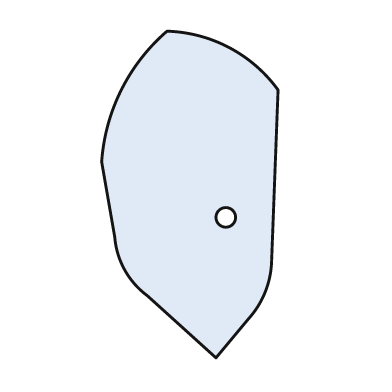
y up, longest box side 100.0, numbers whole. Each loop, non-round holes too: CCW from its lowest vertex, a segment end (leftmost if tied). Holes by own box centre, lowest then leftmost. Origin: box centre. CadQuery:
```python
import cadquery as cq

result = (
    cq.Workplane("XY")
    .moveTo(8.0, -50.0)
    .lineTo(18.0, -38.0)
    .threePointArc((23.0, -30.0), (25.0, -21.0))
    .lineTo(27.0, 32.0)
    .threePointArc((12.0, 45.0), (-7.0, 50.0))
    .threePointArc((-21.0, 32.0), (-27.0, 10.0))
    .lineTo(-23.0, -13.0)
    .threePointArc((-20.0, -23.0), (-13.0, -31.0))
    .close()
    .moveTo(11.0, -7.0)
    .circle(3.0)
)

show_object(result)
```